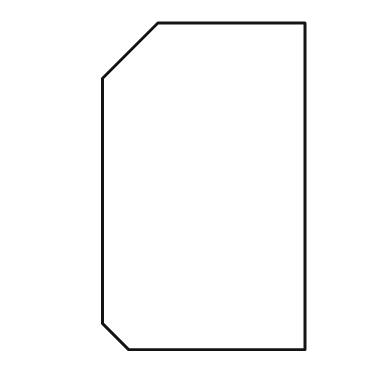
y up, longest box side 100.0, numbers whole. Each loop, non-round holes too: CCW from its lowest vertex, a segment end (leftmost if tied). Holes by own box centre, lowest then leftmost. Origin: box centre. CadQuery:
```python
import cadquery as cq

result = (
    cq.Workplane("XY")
    .moveTo(-23.0, -50.0)
    .lineTo(31.0, -50.0)
    .lineTo(31.0, 50.0)
    .lineTo(-14.0, 50.0)
    .lineTo(-31.0, 33.0)
    .lineTo(-31.0, -42.0)
    .close()
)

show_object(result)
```